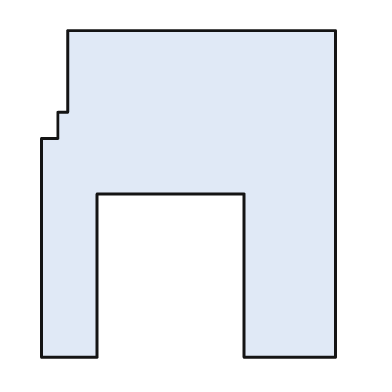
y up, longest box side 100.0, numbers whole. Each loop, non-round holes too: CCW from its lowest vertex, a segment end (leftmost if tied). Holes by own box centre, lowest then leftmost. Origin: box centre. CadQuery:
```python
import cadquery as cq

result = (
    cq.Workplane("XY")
    .moveTo(-45.0, -50.0)
    .lineTo(-28.0, -50.0)
    .lineTo(-28.0, 0.0)
    .lineTo(17.0, 0.0)
    .lineTo(17.0, -50.0)
    .lineTo(45.0, -50.0)
    .lineTo(45.0, 50.0)
    .lineTo(-37.0, 50.0)
    .lineTo(-37.0, 25.0)
    .lineTo(-40.0, 25.0)
    .lineTo(-40.0, 17.0)
    .lineTo(-45.0, 17.0)
    .close()
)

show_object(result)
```